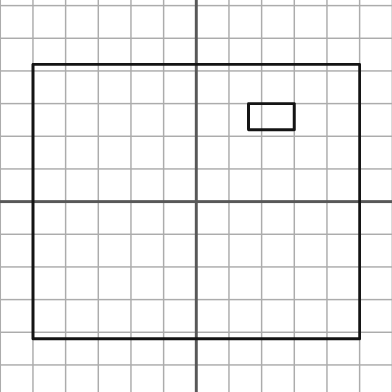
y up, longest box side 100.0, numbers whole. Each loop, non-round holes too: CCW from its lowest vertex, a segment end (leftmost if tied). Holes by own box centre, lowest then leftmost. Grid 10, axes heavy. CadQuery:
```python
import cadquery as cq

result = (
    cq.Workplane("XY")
    .moveTo(-50.0, -42.0)
    .lineTo(50.0, -42.0)
    .lineTo(50.0, 42.0)
    .lineTo(-50.0, 42.0)
    .close()
    .moveTo(16.0, 22.0)
    .lineTo(30.0, 22.0)
    .lineTo(30.0, 30.0)
    .lineTo(16.0, 30.0)
    .close()
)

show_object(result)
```